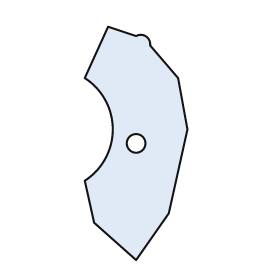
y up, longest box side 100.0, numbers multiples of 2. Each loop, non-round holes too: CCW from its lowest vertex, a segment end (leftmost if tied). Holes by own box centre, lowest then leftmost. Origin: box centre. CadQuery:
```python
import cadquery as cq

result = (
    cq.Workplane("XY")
    .moveTo(0.0, -50.0)
    .lineTo(14.0, -30.0)
    .lineTo(22.0, 6.0)
    .lineTo(18.0, 28.0)
    .lineTo(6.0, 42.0)
    .threePointArc((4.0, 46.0), (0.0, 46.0))
    .lineTo(-12.0, 50.0)
    .lineTo(-22.0, 28.0)
    .threePointArc((-10.0, 6.0), (-22.0, -16.0))
    .lineTo(-18.0, -34.0)
    .close()
    .moveTo(0.0, 0.0)
    .circle(4.0)
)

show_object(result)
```